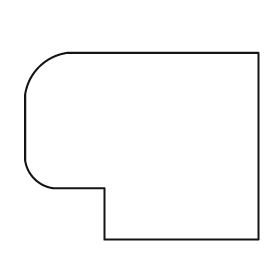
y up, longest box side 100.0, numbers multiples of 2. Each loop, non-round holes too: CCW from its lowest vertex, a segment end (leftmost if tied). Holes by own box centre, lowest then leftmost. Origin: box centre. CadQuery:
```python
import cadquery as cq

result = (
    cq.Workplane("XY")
    .moveTo(-16.0, -40.0)
    .lineTo(50.0, -40.0)
    .lineTo(50.0, 40.0)
    .lineTo(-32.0, 40.0)
    .threePointArc((-44.0, 34.0), (-50.0, 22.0))
    .lineTo(-50.0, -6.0)
    .threePointArc((-46.0, -14.0), (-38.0, -18.0))
    .lineTo(-16.0, -18.0)
    .close()
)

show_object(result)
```